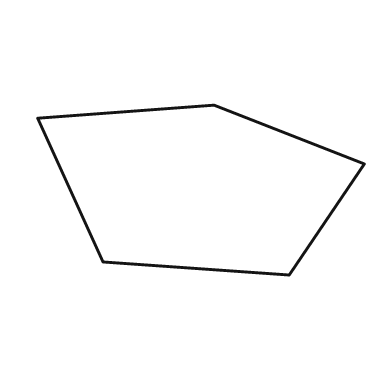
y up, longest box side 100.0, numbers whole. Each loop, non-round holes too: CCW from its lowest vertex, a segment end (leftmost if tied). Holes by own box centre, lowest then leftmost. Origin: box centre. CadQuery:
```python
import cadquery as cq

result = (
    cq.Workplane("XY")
    .moveTo(27.0, -26.0)
    .lineTo(50.0, 8.0)
    .lineTo(4.0, 26.0)
    .lineTo(-50.0, 22.0)
    .lineTo(-30.0, -22.0)
    .close()
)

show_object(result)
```